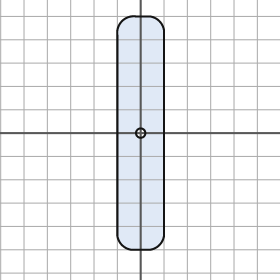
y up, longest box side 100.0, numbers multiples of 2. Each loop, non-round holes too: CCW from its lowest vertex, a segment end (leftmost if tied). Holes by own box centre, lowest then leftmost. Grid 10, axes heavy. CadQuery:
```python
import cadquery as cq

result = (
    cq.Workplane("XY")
    .moveTo(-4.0, -50.0)
    .lineTo(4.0, -50.0)
    .threePointArc((8.0, -48.0), (10.0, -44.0))
    .lineTo(10.0, 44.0)
    .threePointArc((8.0, 48.0), (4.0, 50.0))
    .lineTo(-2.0, 50.0)
    .threePointArc((-8.0, 48.0), (-10.0, 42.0))
    .lineTo(-10.0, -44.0)
    .threePointArc((-8.0, -48.0), (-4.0, -50.0))
    .close()
    .moveTo(0.0, 0.0)
    .circle(2.0)
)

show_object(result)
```